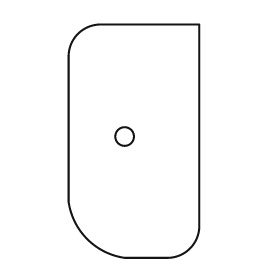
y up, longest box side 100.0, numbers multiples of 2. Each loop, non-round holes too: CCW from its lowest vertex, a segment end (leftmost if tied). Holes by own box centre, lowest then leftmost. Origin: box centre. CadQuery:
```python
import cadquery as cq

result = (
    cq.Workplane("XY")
    .moveTo(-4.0, -50.0)
    .lineTo(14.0, -50.0)
    .threePointArc((24.0, -46.0), (28.0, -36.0))
    .lineTo(28.0, 50.0)
    .lineTo(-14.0, 50.0)
    .threePointArc((-24.0, 46.0), (-28.0, 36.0))
    .lineTo(-28.0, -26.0)
    .threePointArc((-20.0, -42.0), (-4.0, -50.0))
    .close()
    .moveTo(-4.0, 2.0)
    .circle(4.0)
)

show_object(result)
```